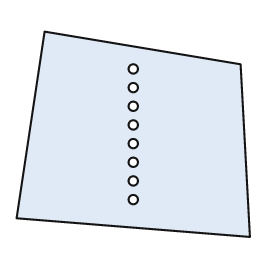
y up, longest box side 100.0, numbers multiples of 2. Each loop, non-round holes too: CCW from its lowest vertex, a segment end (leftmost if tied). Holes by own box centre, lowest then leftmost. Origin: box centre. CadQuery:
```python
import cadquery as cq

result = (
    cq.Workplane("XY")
    .moveTo(50.0, -44.0)
    .lineTo(46.0, 30.0)
    .lineTo(-38.0, 44.0)
    .lineTo(-50.0, -36.0)
    .close()
    .moveTo(0.0, -28.0)
    .circle(2.0)
    .moveTo(0.0, -20.0)
    .circle(2.0)
    .moveTo(0.0, -12.0)
    .circle(2.0)
    .moveTo(0.0, -4.0)
    .circle(2.0)
    .moveTo(0.0, 4.0)
    .circle(2.0)
    .moveTo(0.0, 12.0)
    .circle(2.0)
    .moveTo(0.0, 20.0)
    .circle(2.0)
    .moveTo(0.0, 28.0)
    .circle(2.0)
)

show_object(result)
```